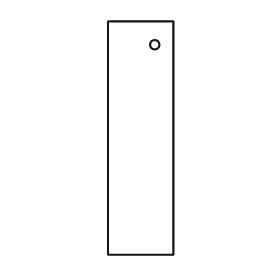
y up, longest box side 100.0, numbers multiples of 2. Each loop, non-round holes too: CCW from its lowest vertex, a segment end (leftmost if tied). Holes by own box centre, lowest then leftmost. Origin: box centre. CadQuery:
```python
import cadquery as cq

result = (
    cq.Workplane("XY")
    .moveTo(-14.0, -50.0)
    .lineTo(14.0, -50.0)
    .lineTo(14.0, 50.0)
    .lineTo(-14.0, 50.0)
    .close()
    .moveTo(6.0, 40.0)
    .circle(2.0)
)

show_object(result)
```